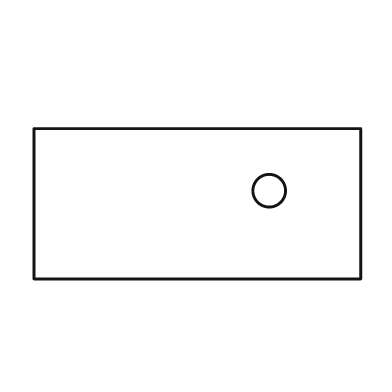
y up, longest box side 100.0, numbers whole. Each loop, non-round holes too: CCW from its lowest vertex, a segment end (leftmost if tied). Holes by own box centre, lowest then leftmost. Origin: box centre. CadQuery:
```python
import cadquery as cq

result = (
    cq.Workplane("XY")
    .moveTo(-50.0, -23.0)
    .lineTo(50.0, -23.0)
    .lineTo(50.0, 23.0)
    .lineTo(-50.0, 23.0)
    .close()
    .moveTo(22.0, 4.0)
    .circle(5.0)
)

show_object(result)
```